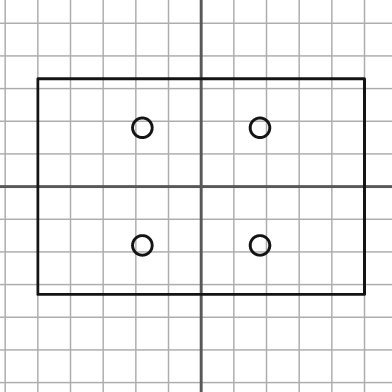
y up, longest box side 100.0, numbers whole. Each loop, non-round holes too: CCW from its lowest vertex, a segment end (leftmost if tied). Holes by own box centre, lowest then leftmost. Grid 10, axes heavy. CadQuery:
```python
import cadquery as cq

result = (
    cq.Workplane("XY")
    .moveTo(-50.0, -33.0)
    .lineTo(50.0, -33.0)
    .lineTo(50.0, 33.0)
    .lineTo(-50.0, 33.0)
    .close()
    .moveTo(-18.0, -18.0)
    .circle(3.0)
    .moveTo(18.0, -18.0)
    .circle(3.0)
    .moveTo(-18.0, 18.0)
    .circle(3.0)
    .moveTo(18.0, 18.0)
    .circle(3.0)
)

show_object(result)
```